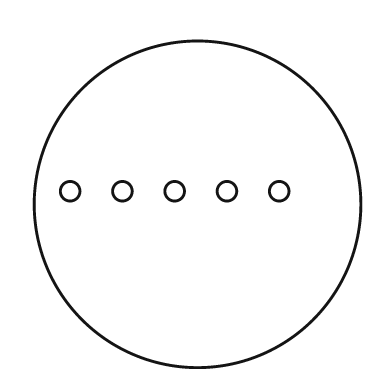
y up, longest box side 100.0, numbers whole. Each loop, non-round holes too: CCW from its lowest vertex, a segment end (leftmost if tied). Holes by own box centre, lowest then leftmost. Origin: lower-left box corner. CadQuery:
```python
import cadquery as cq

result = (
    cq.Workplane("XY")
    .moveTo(50.0, 50.0)
    .circle(50.0)
    .moveTo(11.0, 54.0)
    .circle(3.0)
    .moveTo(27.0, 54.0)
    .circle(3.0)
    .moveTo(43.0, 54.0)
    .circle(3.0)
    .moveTo(59.0, 54.0)
    .circle(3.0)
    .moveTo(75.0, 54.0)
    .circle(3.0)
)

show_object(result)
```